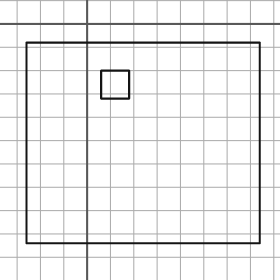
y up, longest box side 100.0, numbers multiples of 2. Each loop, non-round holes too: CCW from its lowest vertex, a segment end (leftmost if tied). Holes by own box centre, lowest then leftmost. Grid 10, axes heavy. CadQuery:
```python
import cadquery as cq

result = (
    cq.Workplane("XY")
    .moveTo(-26.0, -94.0)
    .lineTo(74.0, -94.0)
    .lineTo(74.0, -8.0)
    .lineTo(-26.0, -8.0)
    .close()
    .moveTo(6.0, -32.0)
    .lineTo(18.0, -32.0)
    .lineTo(18.0, -20.0)
    .lineTo(6.0, -20.0)
    .close()
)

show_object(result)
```